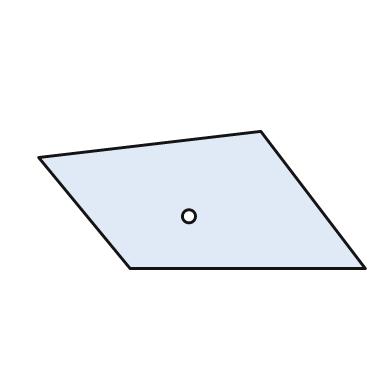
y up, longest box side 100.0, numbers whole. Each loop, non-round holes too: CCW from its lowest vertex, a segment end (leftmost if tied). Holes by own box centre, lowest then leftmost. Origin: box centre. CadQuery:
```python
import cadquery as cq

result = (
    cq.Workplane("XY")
    .moveTo(-22.0, -21.0)
    .lineTo(50.0, -21.0)
    .lineTo(18.0, 21.0)
    .lineTo(-50.0, 13.0)
    .close()
    .moveTo(-4.0, -5.0)
    .circle(2.0)
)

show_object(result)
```